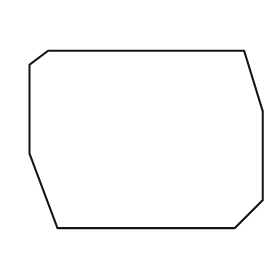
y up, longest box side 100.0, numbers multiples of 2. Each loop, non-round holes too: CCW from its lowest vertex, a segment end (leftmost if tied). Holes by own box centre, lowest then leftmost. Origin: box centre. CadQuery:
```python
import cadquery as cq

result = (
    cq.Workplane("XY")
    .moveTo(-38.0, -38.0)
    .lineTo(38.0, -38.0)
    .lineTo(50.0, -26.0)
    .lineTo(50.0, 12.0)
    .lineTo(42.0, 38.0)
    .lineTo(-42.0, 38.0)
    .lineTo(-50.0, 32.0)
    .lineTo(-50.0, -6.0)
    .close()
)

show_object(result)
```